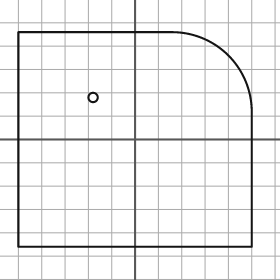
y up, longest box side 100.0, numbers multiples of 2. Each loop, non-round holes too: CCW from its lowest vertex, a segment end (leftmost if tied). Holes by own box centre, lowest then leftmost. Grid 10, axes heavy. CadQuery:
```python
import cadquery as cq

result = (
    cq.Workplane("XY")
    .moveTo(-50.0, -46.0)
    .lineTo(50.0, -46.0)
    .lineTo(50.0, 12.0)
    .threePointArc((40.0, 36.0), (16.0, 46.0))
    .lineTo(-50.0, 46.0)
    .close()
    .moveTo(-18.0, 18.0)
    .circle(2.0)
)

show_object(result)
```